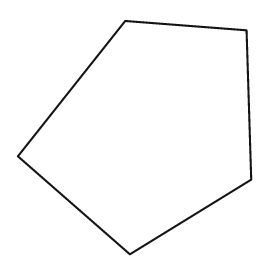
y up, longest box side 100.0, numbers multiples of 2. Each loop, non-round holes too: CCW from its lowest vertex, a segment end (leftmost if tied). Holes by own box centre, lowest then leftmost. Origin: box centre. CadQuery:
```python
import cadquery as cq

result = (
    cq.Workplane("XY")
    .moveTo(-2.0, -50.0)
    .lineTo(50.0, -18.0)
    .lineTo(48.0, 46.0)
    .lineTo(-4.0, 50.0)
    .lineTo(-50.0, -8.0)
    .close()
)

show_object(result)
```